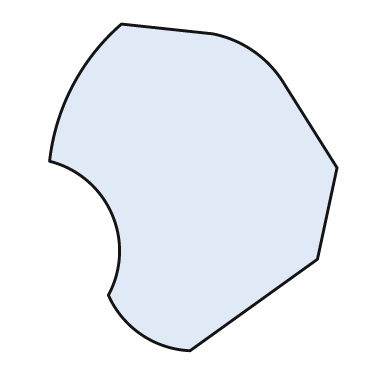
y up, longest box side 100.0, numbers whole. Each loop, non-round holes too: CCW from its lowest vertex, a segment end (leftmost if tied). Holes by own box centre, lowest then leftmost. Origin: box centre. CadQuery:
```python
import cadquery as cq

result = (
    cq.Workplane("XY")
    .moveTo(-1.0, -50.0)
    .lineTo(38.0, -22.0)
    .lineTo(44.0, 6.0)
    .lineTo(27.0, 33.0)
    .threePointArc((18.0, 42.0), (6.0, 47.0))
    .lineTo(-22.0, 50.0)
    .threePointArc((-37.0, 31.0), (-44.0, 8.0))
    .threePointArc((-25.0, -8.0), (-26.0, -33.0))
    .threePointArc((-16.0, -45.0), (-1.0, -50.0))
    .close()
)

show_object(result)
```